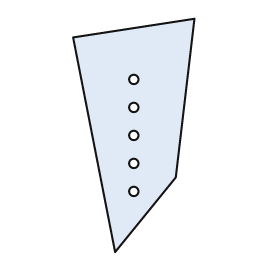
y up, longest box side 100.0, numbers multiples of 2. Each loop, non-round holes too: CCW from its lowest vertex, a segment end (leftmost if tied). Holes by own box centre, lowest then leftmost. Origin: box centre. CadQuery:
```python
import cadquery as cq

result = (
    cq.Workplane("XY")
    .moveTo(-8.0, -50.0)
    .lineTo(18.0, -18.0)
    .lineTo(26.0, 50.0)
    .lineTo(-26.0, 42.0)
    .close()
    .moveTo(0.0, -24.0)
    .circle(2.0)
    .moveTo(0.0, -12.0)
    .circle(2.0)
    .moveTo(0.0, 0.0)
    .circle(2.0)
    .moveTo(0.0, 12.0)
    .circle(2.0)
    .moveTo(0.0, 24.0)
    .circle(2.0)
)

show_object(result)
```